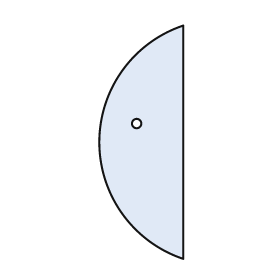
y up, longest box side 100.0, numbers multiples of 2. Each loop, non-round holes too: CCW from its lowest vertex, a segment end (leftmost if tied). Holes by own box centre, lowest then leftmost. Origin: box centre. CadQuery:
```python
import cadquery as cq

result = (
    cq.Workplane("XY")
    .moveTo(18.0, -50.0)
    .lineTo(18.0, 50.0)
    .threePointArc((-18.0, 0.0), (18.0, -50.0))
    .close()
    .moveTo(-2.0, 8.0)
    .circle(2.0)
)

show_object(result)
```